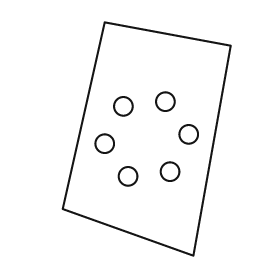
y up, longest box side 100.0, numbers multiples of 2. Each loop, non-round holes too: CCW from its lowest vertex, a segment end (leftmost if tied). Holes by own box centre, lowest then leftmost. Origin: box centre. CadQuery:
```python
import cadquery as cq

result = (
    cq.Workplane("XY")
    .moveTo(20.0, -50.0)
    .lineTo(36.0, 40.0)
    .lineTo(-18.0, 50.0)
    .lineTo(-36.0, -30.0)
    .close()
    .moveTo(-8.0, -16.0)
    .circle(4.0)
    .moveTo(10.0, -14.0)
    .circle(4.0)
    .moveTo(-18.0, -2.0)
    .circle(4.0)
    .moveTo(18.0, 2.0)
    .circle(4.0)
    .moveTo(-10.0, 14.0)
    .circle(4.0)
    .moveTo(8.0, 16.0)
    .circle(4.0)
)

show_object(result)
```